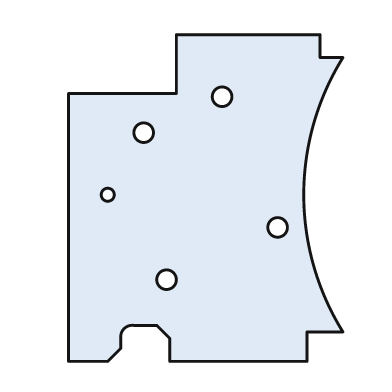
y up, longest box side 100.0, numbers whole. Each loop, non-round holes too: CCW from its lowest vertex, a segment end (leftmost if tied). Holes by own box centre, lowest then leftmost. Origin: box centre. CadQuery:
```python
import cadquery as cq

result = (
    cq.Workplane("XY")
    .moveTo(-42.0, -50.0)
    .lineTo(-30.0, -50.0)
    .lineTo(-26.0, -46.0)
    .lineTo(-26.0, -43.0)
    .threePointArc((-25.0, -40.0), (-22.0, -39.0))
    .lineTo(-15.0, -39.0)
    .lineTo(-11.0, -43.0)
    .lineTo(-11.0, -50.0)
    .lineTo(31.0, -50.0)
    .lineTo(31.0, -41.0)
    .lineTo(42.0, -41.0)
    .threePointArc((30.0, 1.0), (42.0, 43.0))
    .lineTo(35.0, 43.0)
    .lineTo(35.0, 50.0)
    .lineTo(-9.0, 50.0)
    .lineTo(-9.0, 32.0)
    .lineTo(-42.0, 32.0)
    .close()
    .moveTo(-12.0, -25.0)
    .circle(3.0)
    .moveTo(22.0, -9.0)
    .circle(3.0)
    .moveTo(-30.0, 1.0)
    .circle(2.0)
    .moveTo(-19.0, 20.0)
    .circle(3.0)
    .moveTo(5.0, 31.0)
    .circle(3.0)
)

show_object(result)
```